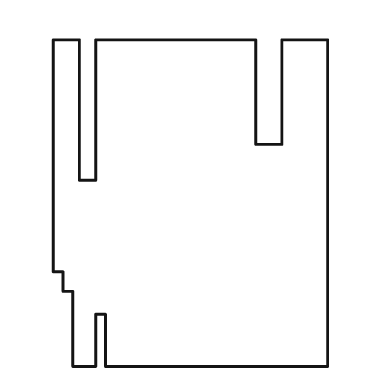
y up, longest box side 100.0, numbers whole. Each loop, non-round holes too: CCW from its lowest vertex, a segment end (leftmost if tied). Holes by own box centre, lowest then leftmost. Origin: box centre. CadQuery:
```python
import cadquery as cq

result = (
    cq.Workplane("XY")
    .moveTo(-36.0, -50.0)
    .lineTo(-29.0, -50.0)
    .lineTo(-29.0, -34.0)
    .lineTo(-26.0, -34.0)
    .lineTo(-26.0, -50.0)
    .lineTo(42.0, -50.0)
    .lineTo(42.0, 50.0)
    .lineTo(28.0, 50.0)
    .lineTo(28.0, 18.0)
    .lineTo(20.0, 18.0)
    .lineTo(20.0, 50.0)
    .lineTo(-29.0, 50.0)
    .lineTo(-29.0, 7.0)
    .lineTo(-34.0, 7.0)
    .lineTo(-34.0, 50.0)
    .lineTo(-42.0, 50.0)
    .lineTo(-42.0, -21.0)
    .lineTo(-39.0, -21.0)
    .lineTo(-39.0, -27.0)
    .lineTo(-36.0, -27.0)
    .close()
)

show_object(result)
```